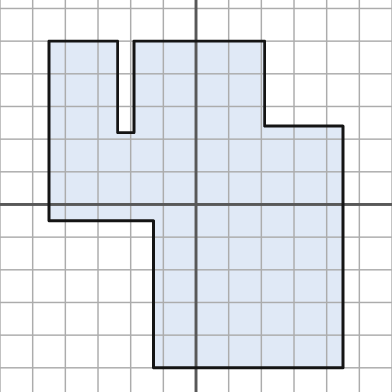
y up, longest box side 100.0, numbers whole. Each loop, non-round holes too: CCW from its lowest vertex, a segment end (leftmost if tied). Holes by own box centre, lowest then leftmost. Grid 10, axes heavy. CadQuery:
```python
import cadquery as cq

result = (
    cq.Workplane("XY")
    .moveTo(-13.0, -50.0)
    .lineTo(45.0, -50.0)
    .lineTo(45.0, 24.0)
    .lineTo(21.0, 24.0)
    .lineTo(21.0, 50.0)
    .lineTo(-19.0, 50.0)
    .lineTo(-19.0, 22.0)
    .lineTo(-24.0, 22.0)
    .lineTo(-24.0, 50.0)
    .lineTo(-45.0, 50.0)
    .lineTo(-45.0, -5.0)
    .lineTo(-13.0, -5.0)
    .close()
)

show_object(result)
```